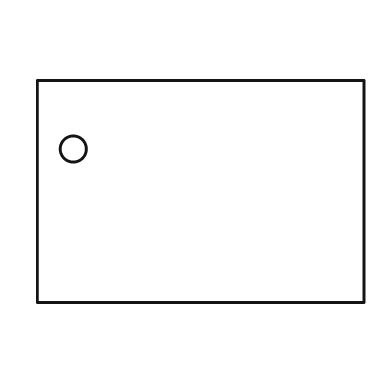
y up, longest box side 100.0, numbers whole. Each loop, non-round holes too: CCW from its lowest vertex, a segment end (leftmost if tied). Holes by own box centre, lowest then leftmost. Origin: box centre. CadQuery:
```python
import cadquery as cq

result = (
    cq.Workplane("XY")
    .moveTo(-50.0, -34.0)
    .lineTo(50.0, -34.0)
    .lineTo(50.0, 34.0)
    .lineTo(-50.0, 34.0)
    .close()
    .moveTo(-39.0, 13.0)
    .circle(4.0)
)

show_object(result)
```